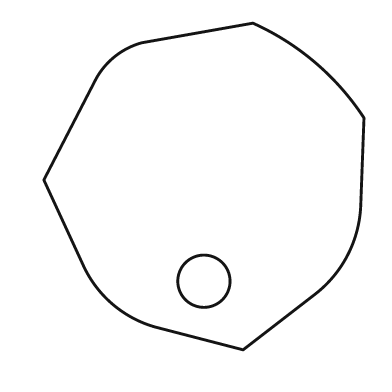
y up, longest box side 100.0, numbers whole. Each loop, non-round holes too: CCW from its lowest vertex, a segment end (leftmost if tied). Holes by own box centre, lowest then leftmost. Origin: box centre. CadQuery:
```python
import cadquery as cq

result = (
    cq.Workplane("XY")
    .moveTo(12.0, -50.0)
    .lineTo(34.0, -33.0)
    .threePointArc((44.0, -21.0), (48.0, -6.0))
    .lineTo(49.0, 21.0)
    .threePointArc((34.0, 38.0), (15.0, 50.0))
    .lineTo(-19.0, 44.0)
    .threePointArc((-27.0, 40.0), (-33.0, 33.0))
    .lineTo(-49.0, 2.0)
    .lineTo(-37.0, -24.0)
    .threePointArc((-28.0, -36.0), (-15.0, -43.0))
    .close()
    .moveTo(0.0, -29.0)
    .circle(8.0)
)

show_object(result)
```